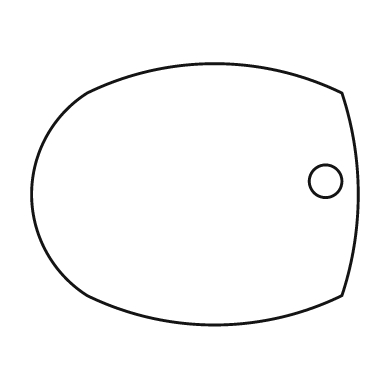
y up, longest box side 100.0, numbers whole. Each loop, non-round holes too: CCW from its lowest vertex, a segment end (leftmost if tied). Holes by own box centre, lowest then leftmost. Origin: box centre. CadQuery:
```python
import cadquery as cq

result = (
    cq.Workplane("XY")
    .moveTo(-33.0, -31.0)
    .threePointArc((6.0, -40.0), (45.0, -31.0))
    .threePointArc((50.0, 0.0), (45.0, 31.0))
    .threePointArc((6.0, 40.0), (-33.0, 31.0))
    .threePointArc((-50.0, 0.0), (-33.0, -31.0))
    .close()
    .moveTo(40.0, 4.0)
    .circle(5.0)
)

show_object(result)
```